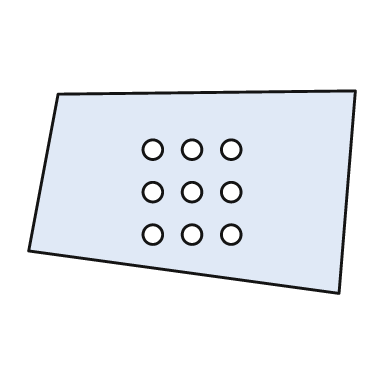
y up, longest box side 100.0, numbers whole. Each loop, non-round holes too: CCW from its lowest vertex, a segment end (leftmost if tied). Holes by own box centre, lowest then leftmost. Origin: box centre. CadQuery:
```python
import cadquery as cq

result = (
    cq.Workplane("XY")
    .moveTo(45.0, -31.0)
    .lineTo(50.0, 31.0)
    .lineTo(-41.0, 30.0)
    .lineTo(-50.0, -18.0)
    .close()
    .moveTo(-12.0, -13.0)
    .circle(3.0)
    .moveTo(0.0, -13.0)
    .circle(3.0)
    .moveTo(12.0, -13.0)
    .circle(3.0)
    .moveTo(-12.0, 0.0)
    .circle(3.0)
    .moveTo(0.0, 0.0)
    .circle(3.0)
    .moveTo(12.0, 0.0)
    .circle(3.0)
    .moveTo(-12.0, 13.0)
    .circle(3.0)
    .moveTo(0.0, 13.0)
    .circle(3.0)
    .moveTo(12.0, 13.0)
    .circle(3.0)
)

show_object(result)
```